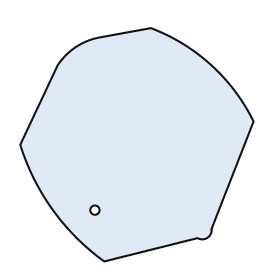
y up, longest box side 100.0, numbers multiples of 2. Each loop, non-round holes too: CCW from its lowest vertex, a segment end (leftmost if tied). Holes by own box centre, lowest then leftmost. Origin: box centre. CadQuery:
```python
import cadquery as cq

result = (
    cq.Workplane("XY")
    .moveTo(-14.0, -50.0)
    .lineTo(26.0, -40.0)
    .threePointArc((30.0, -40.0), (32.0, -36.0))
    .lineTo(50.0, 10.0)
    .threePointArc((32.0, 34.0), (6.0, 50.0))
    .lineTo(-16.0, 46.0)
    .threePointArc((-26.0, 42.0), (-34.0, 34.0))
    .lineTo(-50.0, 0.0)
    .threePointArc((-36.0, -28.0), (-14.0, -50.0))
    .close()
    .moveTo(-18.0, -28.0)
    .circle(2.0)
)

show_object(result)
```